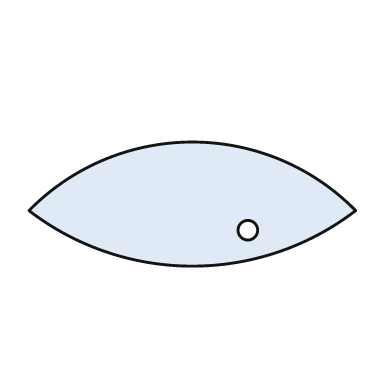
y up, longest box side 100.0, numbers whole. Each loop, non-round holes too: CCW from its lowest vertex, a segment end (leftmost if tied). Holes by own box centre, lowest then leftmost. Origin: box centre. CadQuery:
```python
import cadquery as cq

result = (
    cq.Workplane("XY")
    .moveTo(-50.0, -2.0)
    .threePointArc((0.0, -19.0), (50.0, -2.0))
    .threePointArc((0.0, 19.0), (-50.0, -2.0))
    .close()
    .moveTo(17.0, -8.0)
    .circle(3.0)
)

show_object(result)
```